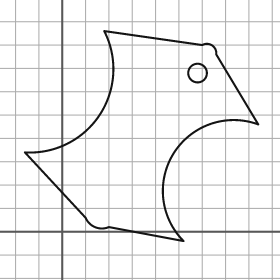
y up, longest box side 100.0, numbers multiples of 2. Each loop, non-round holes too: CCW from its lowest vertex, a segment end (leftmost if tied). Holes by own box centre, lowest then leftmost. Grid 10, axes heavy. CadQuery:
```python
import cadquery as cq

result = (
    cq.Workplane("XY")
    .moveTo(52.0, -4.0)
    .threePointArc((48.0, 34.0), (84.0, 46.0))
    .lineTo(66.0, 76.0)
    .threePointArc((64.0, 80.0), (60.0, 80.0))
    .lineTo(18.0, 86.0)
    .threePointArc((16.0, 50.0), (-16.0, 34.0))
    .lineTo(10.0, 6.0)
    .threePointArc((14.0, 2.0), (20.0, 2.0))
    .close()
    .moveTo(58.0, 68.0)
    .circle(4.0)
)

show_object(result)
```